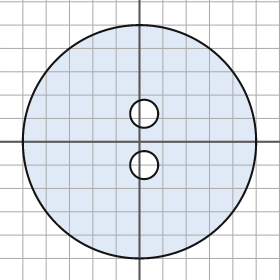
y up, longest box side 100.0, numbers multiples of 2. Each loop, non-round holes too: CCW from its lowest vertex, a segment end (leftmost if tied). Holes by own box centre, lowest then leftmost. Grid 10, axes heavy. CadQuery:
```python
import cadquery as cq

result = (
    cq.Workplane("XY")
    .moveTo(0.0, 0.0)
    .circle(50.0)
    .moveTo(2.0, -10.0)
    .circle(6.0)
    .moveTo(2.0, 12.0)
    .circle(6.0)
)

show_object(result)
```